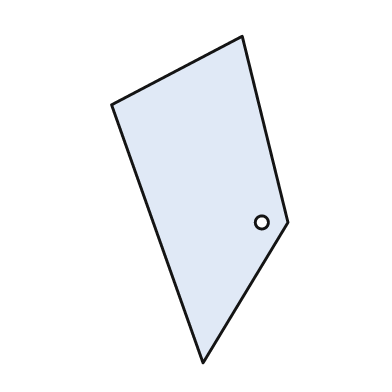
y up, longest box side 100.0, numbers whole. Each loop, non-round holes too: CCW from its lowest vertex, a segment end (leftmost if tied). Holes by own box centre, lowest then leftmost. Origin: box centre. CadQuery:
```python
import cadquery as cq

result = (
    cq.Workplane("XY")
    .moveTo(1.0, -50.0)
    .lineTo(27.0, -7.0)
    .lineTo(13.0, 50.0)
    .lineTo(-27.0, 29.0)
    .close()
    .moveTo(19.0, -7.0)
    .circle(2.0)
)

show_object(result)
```